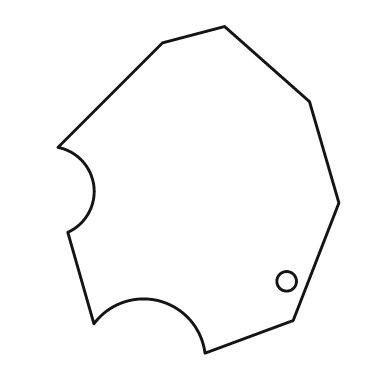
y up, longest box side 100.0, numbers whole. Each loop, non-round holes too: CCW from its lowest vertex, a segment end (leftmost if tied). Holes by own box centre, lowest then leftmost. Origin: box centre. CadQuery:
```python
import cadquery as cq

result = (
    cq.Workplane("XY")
    .moveTo(2.0, -50.0)
    .lineTo(29.0, -40.0)
    .lineTo(43.0, -4.0)
    .lineTo(34.0, 27.0)
    .lineTo(8.0, 50.0)
    .lineTo(-11.0, 45.0)
    .lineTo(-43.0, 13.0)
    .threePointArc((-32.0, 1.0), (-40.0, -13.0))
    .lineTo(-32.0, -41.0)
    .threePointArc((-12.0, -34.0), (2.0, -50.0))
    .close()
    .moveTo(27.0, -28.0)
    .circle(3.0)
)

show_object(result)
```